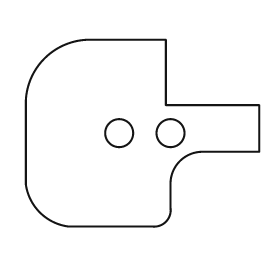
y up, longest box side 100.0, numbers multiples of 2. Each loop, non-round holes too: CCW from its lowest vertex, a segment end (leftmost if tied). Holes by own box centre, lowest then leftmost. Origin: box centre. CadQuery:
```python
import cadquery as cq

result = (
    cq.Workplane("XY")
    .moveTo(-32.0, -40.0)
    .lineTo(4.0, -40.0)
    .threePointArc((10.0, -38.0), (12.0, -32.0))
    .lineTo(12.0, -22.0)
    .threePointArc((16.0, -12.0), (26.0, -8.0))
    .lineTo(50.0, -8.0)
    .lineTo(50.0, 12.0)
    .lineTo(10.0, 12.0)
    .lineTo(10.0, 40.0)
    .lineTo(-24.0, 40.0)
    .threePointArc((-42.0, 32.0), (-50.0, 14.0))
    .lineTo(-50.0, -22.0)
    .threePointArc((-44.0, -34.0), (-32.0, -40.0))
    .close()
    .moveTo(-10.0, 0.0)
    .circle(6.0)
    .moveTo(12.0, 0.0)
    .circle(6.0)
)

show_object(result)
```